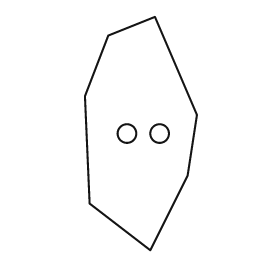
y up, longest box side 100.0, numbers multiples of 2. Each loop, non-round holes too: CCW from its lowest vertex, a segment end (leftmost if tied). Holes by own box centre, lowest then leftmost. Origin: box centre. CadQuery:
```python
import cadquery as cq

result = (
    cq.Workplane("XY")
    .moveTo(4.0, -50.0)
    .lineTo(20.0, -18.0)
    .lineTo(24.0, 8.0)
    .lineTo(6.0, 50.0)
    .lineTo(-14.0, 42.0)
    .lineTo(-24.0, 16.0)
    .lineTo(-22.0, -30.0)
    .close()
    .moveTo(-6.0, 0.0)
    .circle(4.0)
    .moveTo(8.0, 0.0)
    .circle(4.0)
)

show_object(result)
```